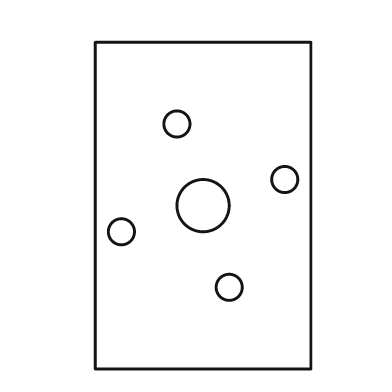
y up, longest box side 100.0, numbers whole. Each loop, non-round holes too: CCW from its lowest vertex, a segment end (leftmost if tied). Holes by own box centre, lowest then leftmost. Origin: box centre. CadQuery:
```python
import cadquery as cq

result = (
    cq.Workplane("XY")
    .moveTo(-33.0, -50.0)
    .lineTo(33.0, -50.0)
    .lineTo(33.0, 50.0)
    .lineTo(-33.0, 50.0)
    .close()
    .moveTo(8.0, -25.0)
    .circle(4.0)
    .moveTo(-25.0, -8.0)
    .circle(4.0)
    .moveTo(0.0, 0.0)
    .circle(8.0)
    .moveTo(25.0, 8.0)
    .circle(4.0)
    .moveTo(-8.0, 25.0)
    .circle(4.0)
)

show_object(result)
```